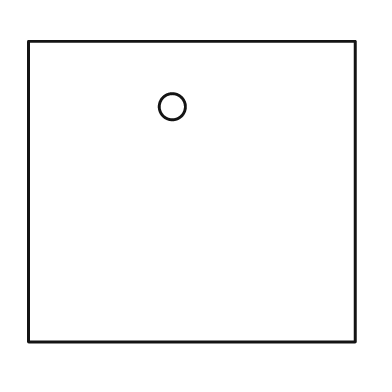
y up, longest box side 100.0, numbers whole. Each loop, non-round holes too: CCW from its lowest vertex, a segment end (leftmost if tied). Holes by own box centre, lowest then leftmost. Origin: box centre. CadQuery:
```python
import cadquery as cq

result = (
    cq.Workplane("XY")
    .moveTo(-50.0, -46.0)
    .lineTo(50.0, -46.0)
    .lineTo(50.0, 46.0)
    .lineTo(-50.0, 46.0)
    .close()
    .moveTo(-6.0, 26.0)
    .circle(4.0)
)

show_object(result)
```